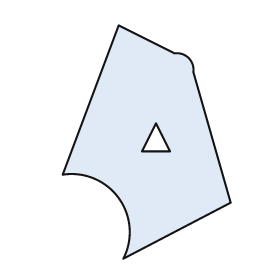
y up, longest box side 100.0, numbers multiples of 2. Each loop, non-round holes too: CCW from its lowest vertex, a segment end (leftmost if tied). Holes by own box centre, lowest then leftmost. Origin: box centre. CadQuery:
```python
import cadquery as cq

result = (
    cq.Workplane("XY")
    .moveTo(-10.0, -50.0)
    .lineTo(36.0, -26.0)
    .lineTo(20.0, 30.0)
    .threePointArc((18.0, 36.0), (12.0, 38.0))
    .lineTo(-12.0, 50.0)
    .lineTo(-36.0, -14.0)
    .threePointArc((-12.0, -24.0), (-10.0, -50.0))
    .close()
    .moveTo(-2.0, -4.0)
    .lineTo(10.0, -4.0)
    .lineTo(4.0, 8.0)
    .close()
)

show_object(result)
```